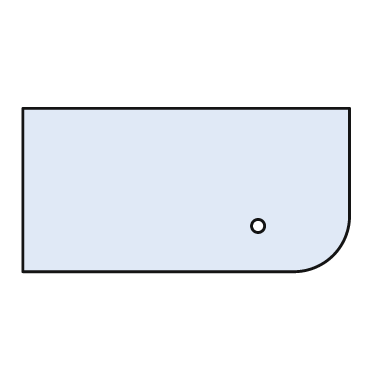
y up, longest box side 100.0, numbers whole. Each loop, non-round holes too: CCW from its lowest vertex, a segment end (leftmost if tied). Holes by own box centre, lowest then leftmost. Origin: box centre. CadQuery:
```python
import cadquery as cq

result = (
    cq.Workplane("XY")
    .moveTo(-50.0, -25.0)
    .lineTo(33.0, -25.0)
    .threePointArc((45.0, -20.0), (50.0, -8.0))
    .lineTo(50.0, 25.0)
    .lineTo(-50.0, 25.0)
    .close()
    .moveTo(22.0, -11.0)
    .circle(2.0)
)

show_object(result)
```